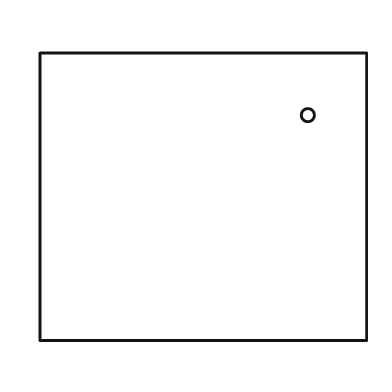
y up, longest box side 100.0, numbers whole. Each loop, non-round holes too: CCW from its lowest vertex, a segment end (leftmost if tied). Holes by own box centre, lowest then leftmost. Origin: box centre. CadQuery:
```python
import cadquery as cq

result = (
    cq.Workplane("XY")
    .moveTo(-50.0, -44.0)
    .lineTo(50.0, -44.0)
    .lineTo(50.0, 44.0)
    .lineTo(-50.0, 44.0)
    .close()
    .moveTo(32.0, 25.0)
    .circle(2.0)
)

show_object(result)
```